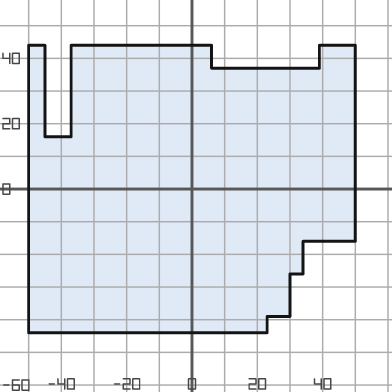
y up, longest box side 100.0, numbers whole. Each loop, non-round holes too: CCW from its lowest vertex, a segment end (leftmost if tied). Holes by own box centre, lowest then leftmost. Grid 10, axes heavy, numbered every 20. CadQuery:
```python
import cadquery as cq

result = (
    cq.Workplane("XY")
    .moveTo(-50.0, -44.0)
    .lineTo(23.0, -44.0)
    .lineTo(23.0, -39.0)
    .lineTo(30.0, -39.0)
    .lineTo(30.0, -26.0)
    .lineTo(34.0, -26.0)
    .lineTo(34.0, -16.0)
    .lineTo(50.0, -16.0)
    .lineTo(50.0, 44.0)
    .lineTo(39.0, 44.0)
    .lineTo(39.0, 37.0)
    .lineTo(6.0, 37.0)
    .lineTo(6.0, 44.0)
    .lineTo(-37.0, 44.0)
    .lineTo(-37.0, 16.0)
    .lineTo(-45.0, 16.0)
    .lineTo(-45.0, 44.0)
    .lineTo(-50.0, 44.0)
    .close()
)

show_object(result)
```